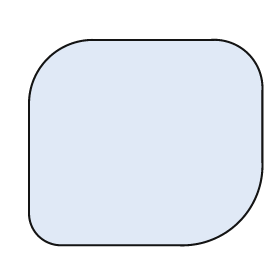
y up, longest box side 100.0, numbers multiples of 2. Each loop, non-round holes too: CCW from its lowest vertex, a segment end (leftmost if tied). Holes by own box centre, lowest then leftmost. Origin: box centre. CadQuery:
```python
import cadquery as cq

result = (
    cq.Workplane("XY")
    .moveTo(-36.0, -44.0)
    .lineTo(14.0, -44.0)
    .threePointArc((40.0, -34.0), (50.0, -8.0))
    .lineTo(50.0, 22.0)
    .threePointArc((44.0, 38.0), (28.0, 44.0))
    .lineTo(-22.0, 44.0)
    .threePointArc((-42.0, 36.0), (-50.0, 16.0))
    .lineTo(-50.0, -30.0)
    .threePointArc((-46.0, -40.0), (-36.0, -44.0))
    .close()
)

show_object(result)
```